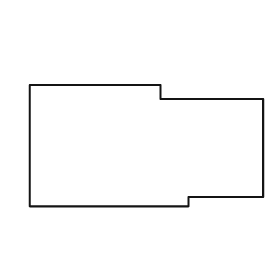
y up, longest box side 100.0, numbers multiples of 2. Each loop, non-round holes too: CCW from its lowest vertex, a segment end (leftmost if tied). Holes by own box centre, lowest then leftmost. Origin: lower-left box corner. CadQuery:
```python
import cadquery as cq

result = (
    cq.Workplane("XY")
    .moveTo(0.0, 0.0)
    .lineTo(68.0, 0.0)
    .lineTo(68.0, 4.0)
    .lineTo(100.0, 4.0)
    .lineTo(100.0, 46.0)
    .lineTo(56.0, 46.0)
    .lineTo(56.0, 52.0)
    .lineTo(0.0, 52.0)
    .close()
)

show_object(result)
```